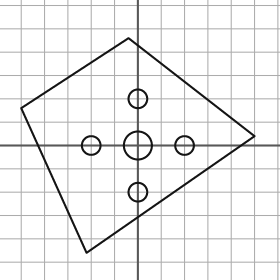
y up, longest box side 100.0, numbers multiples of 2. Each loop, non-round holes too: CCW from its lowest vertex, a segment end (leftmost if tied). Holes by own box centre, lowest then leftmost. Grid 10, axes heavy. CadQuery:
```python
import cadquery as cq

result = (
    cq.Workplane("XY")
    .moveTo(-22.0, -46.0)
    .lineTo(50.0, 4.0)
    .lineTo(-4.0, 46.0)
    .lineTo(-50.0, 16.0)
    .close()
    .moveTo(0.0, -20.0)
    .circle(4.0)
    .moveTo(-20.0, 0.0)
    .circle(4.0)
    .moveTo(0.0, 0.0)
    .circle(6.0)
    .moveTo(20.0, 0.0)
    .circle(4.0)
    .moveTo(0.0, 20.0)
    .circle(4.0)
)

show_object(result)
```